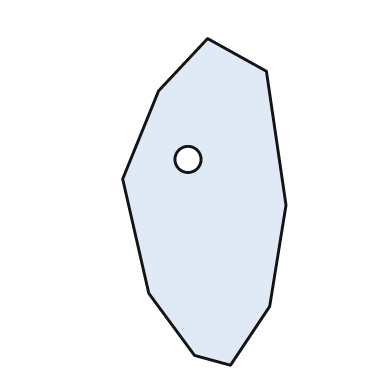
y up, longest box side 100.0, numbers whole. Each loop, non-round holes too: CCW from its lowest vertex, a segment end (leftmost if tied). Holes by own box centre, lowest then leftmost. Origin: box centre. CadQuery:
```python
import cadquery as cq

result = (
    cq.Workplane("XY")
    .moveTo(8.0, -50.0)
    .lineTo(20.0, -32.0)
    .lineTo(25.0, -1.0)
    .lineTo(19.0, 40.0)
    .lineTo(1.0, 50.0)
    .lineTo(-14.0, 34.0)
    .lineTo(-25.0, 7.0)
    .lineTo(-17.0, -28.0)
    .lineTo(-3.0, -47.0)
    .close()
    .moveTo(-5.0, 13.0)
    .circle(4.0)
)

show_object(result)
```